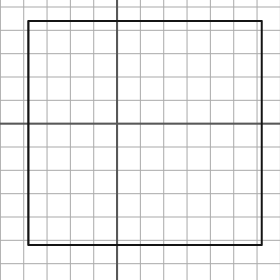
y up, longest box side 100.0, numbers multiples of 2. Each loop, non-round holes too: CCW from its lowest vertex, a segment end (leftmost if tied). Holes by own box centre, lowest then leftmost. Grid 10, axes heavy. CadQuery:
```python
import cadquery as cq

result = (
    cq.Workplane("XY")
    .moveTo(-38.0, -52.0)
    .lineTo(62.0, -52.0)
    .lineTo(62.0, 44.0)
    .lineTo(-38.0, 44.0)
    .close()
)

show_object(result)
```